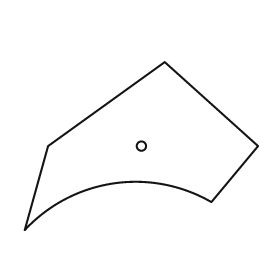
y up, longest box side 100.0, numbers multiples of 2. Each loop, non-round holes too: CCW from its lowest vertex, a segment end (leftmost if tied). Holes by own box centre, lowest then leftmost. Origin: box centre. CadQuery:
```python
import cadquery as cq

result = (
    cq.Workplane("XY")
    .moveTo(-50.0, -36.0)
    .threePointArc((-12.0, -16.0), (30.0, -24.0))
    .lineTo(50.0, 0.0)
    .lineTo(10.0, 36.0)
    .lineTo(-40.0, 0.0)
    .close()
    .moveTo(0.0, 0.0)
    .circle(2.0)
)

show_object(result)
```